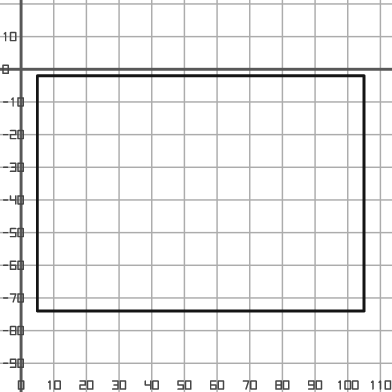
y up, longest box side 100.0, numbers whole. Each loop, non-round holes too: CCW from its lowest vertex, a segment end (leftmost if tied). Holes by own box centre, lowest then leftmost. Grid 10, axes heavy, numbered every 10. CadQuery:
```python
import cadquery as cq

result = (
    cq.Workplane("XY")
    .moveTo(5.0, -74.0)
    .lineTo(105.0, -74.0)
    .lineTo(105.0, -2.0)
    .lineTo(5.0, -2.0)
    .close()
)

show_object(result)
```